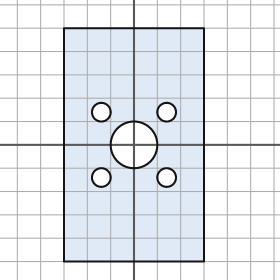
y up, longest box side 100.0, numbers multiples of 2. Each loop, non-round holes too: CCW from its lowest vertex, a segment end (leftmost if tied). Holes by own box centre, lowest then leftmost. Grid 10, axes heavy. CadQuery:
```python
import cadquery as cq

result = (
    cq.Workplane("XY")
    .moveTo(-30.0, -50.0)
    .lineTo(30.0, -50.0)
    .lineTo(30.0, 50.0)
    .lineTo(-30.0, 50.0)
    .close()
    .moveTo(-14.0, -14.0)
    .circle(4.0)
    .moveTo(14.0, -14.0)
    .circle(4.0)
    .moveTo(0.0, 0.0)
    .circle(10.0)
    .moveTo(-14.0, 14.0)
    .circle(4.0)
    .moveTo(14.0, 14.0)
    .circle(4.0)
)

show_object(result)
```